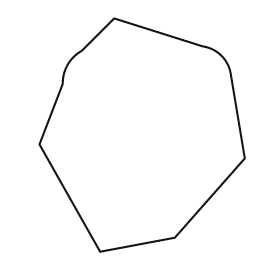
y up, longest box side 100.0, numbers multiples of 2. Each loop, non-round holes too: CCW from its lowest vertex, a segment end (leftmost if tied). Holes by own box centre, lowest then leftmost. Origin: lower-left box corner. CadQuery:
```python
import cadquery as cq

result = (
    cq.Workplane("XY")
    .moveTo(26.0, 0.0)
    .lineTo(58.0, 6.0)
    .lineTo(88.0, 40.0)
    .lineTo(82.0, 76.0)
    .threePointArc((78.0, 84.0), (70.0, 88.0))
    .lineTo(32.0, 100.0)
    .lineTo(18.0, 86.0)
    .threePointArc((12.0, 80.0), (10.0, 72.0))
    .lineTo(0.0, 46.0)
    .close()
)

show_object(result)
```